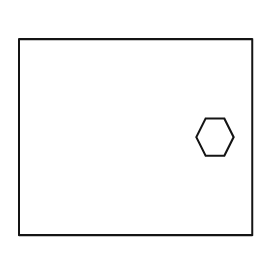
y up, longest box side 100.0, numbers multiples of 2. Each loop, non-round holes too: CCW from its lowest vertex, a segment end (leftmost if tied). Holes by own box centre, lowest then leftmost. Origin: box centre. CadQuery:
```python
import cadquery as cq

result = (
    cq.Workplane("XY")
    .moveTo(-50.0, -42.0)
    .lineTo(50.0, -42.0)
    .lineTo(50.0, 42.0)
    .lineTo(-50.0, 42.0)
    .close()
    .moveTo(30.0, -8.0)
    .lineTo(38.0, -8.0)
    .lineTo(42.0, 0.0)
    .lineTo(38.0, 8.0)
    .lineTo(30.0, 8.0)
    .lineTo(26.0, 0.0)
    .close()
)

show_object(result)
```